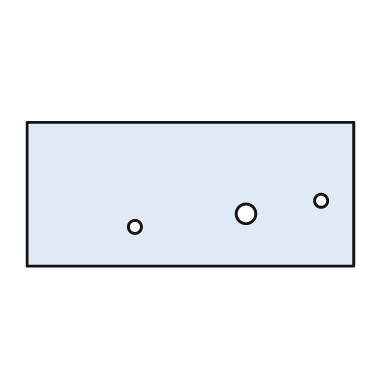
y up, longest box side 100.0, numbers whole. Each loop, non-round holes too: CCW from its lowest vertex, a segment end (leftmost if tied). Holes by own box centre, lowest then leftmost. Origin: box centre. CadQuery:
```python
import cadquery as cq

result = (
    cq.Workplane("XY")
    .moveTo(-50.0, -22.0)
    .lineTo(50.0, -22.0)
    .lineTo(50.0, 22.0)
    .lineTo(-50.0, 22.0)
    .close()
    .moveTo(-17.0, -10.0)
    .circle(2.0)
    .moveTo(17.0, -6.0)
    .circle(3.0)
    .moveTo(40.0, -2.0)
    .circle(2.0)
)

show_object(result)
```